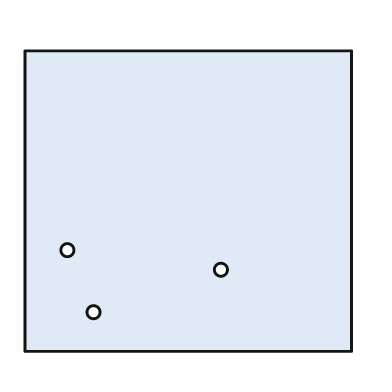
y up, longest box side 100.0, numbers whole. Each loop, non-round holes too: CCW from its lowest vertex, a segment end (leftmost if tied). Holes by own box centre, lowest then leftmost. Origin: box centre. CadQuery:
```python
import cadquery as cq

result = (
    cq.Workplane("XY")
    .moveTo(-50.0, -46.0)
    .lineTo(50.0, -46.0)
    .lineTo(50.0, 46.0)
    .lineTo(-50.0, 46.0)
    .close()
    .moveTo(-29.0, -34.0)
    .circle(2.0)
    .moveTo(10.0, -21.0)
    .circle(2.0)
    .moveTo(-37.0, -15.0)
    .circle(2.0)
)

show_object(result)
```